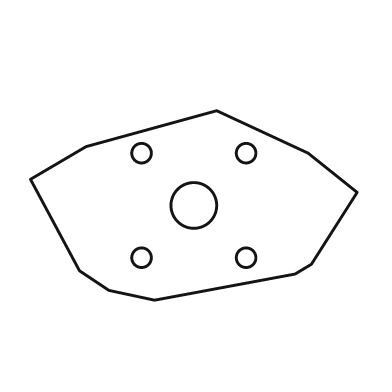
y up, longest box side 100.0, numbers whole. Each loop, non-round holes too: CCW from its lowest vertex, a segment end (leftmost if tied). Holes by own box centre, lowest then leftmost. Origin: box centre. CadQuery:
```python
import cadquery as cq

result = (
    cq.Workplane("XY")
    .moveTo(-12.0, -29.0)
    .lineTo(31.0, -21.0)
    .lineTo(36.0, -18.0)
    .lineTo(50.0, 4.0)
    .lineTo(35.0, 16.0)
    .lineTo(7.0, 29.0)
    .lineTo(-33.0, 18.0)
    .lineTo(-50.0, 8.0)
    .lineTo(-35.0, -20.0)
    .lineTo(-26.0, -26.0)
    .close()
    .moveTo(-16.0, -16.0)
    .circle(3.0)
    .moveTo(16.0, -16.0)
    .circle(3.0)
    .moveTo(0.0, 0.0)
    .circle(7.0)
    .moveTo(-16.0, 16.0)
    .circle(3.0)
    .moveTo(16.0, 16.0)
    .circle(3.0)
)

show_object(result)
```